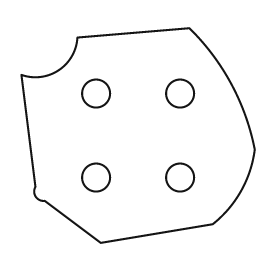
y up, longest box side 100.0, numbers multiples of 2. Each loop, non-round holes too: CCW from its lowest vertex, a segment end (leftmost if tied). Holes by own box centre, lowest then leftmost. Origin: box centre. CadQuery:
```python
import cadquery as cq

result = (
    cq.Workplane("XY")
    .moveTo(-16.0, -46.0)
    .lineTo(32.0, -38.0)
    .threePointArc((44.0, -24.0), (50.0, -6.0))
    .threePointArc((40.0, 22.0), (22.0, 46.0))
    .lineTo(-26.0, 42.0)
    .threePointArc((-34.0, 28.0), (-50.0, 26.0))
    .lineTo(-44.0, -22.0)
    .threePointArc((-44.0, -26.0), (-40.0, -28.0))
    .close()
    .moveTo(-18.0, -18.0)
    .circle(6.0)
    .moveTo(18.0, -18.0)
    .circle(6.0)
    .moveTo(-18.0, 18.0)
    .circle(6.0)
    .moveTo(18.0, 18.0)
    .circle(6.0)
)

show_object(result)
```